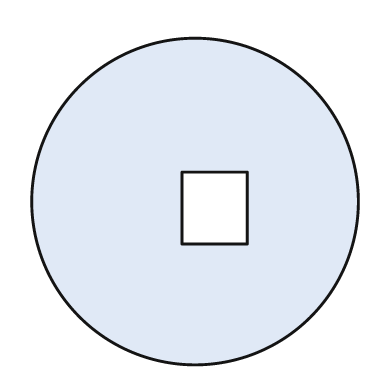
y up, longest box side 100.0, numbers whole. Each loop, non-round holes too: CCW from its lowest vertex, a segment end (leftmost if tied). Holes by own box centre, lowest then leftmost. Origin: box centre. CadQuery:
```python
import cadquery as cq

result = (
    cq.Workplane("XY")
    .moveTo(0.0, 0.0)
    .circle(50.0)
    .moveTo(-4.0, -13.0)
    .lineTo(16.0, -13.0)
    .lineTo(16.0, 9.0)
    .lineTo(-4.0, 9.0)
    .close()
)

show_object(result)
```